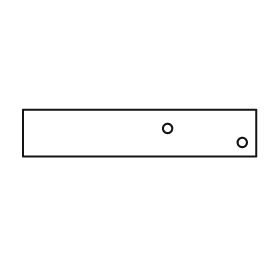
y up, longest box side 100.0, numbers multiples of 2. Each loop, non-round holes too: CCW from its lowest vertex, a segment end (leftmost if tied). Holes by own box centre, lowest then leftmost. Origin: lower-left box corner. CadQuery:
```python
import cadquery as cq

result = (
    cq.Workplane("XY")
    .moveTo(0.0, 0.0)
    .lineTo(100.0, 0.0)
    .lineTo(100.0, 20.0)
    .lineTo(0.0, 20.0)
    .close()
    .moveTo(94.0, 6.0)
    .circle(2.0)
    .moveTo(62.0, 12.0)
    .circle(2.0)
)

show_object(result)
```